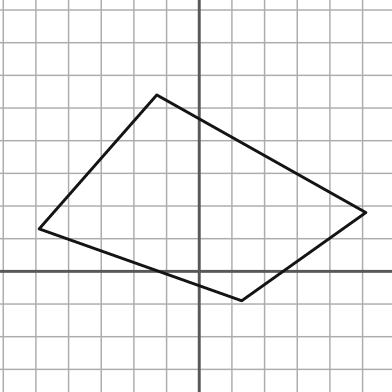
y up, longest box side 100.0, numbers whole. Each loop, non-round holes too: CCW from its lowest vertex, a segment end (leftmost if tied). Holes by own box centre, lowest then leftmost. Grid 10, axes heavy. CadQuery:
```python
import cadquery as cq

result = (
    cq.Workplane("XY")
    .moveTo(13.0, -9.0)
    .lineTo(51.0, 18.0)
    .lineTo(-13.0, 54.0)
    .lineTo(-49.0, 13.0)
    .close()
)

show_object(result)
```